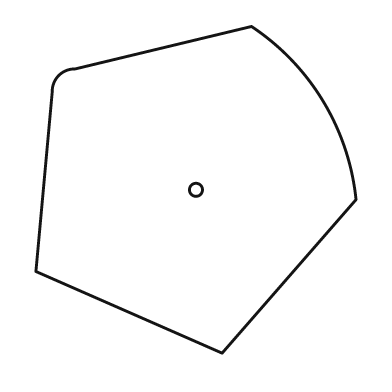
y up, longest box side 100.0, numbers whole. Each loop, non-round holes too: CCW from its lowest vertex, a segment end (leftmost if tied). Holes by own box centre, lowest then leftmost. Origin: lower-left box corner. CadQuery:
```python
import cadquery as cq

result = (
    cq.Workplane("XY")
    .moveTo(57.0, 0.0)
    .lineTo(98.0, 47.0)
    .threePointArc((88.0, 77.0), (66.0, 100.0))
    .lineTo(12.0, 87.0)
    .threePointArc((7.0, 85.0), (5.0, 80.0))
    .lineTo(0.0, 25.0)
    .close()
    .moveTo(49.0, 50.0)
    .circle(2.0)
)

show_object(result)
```